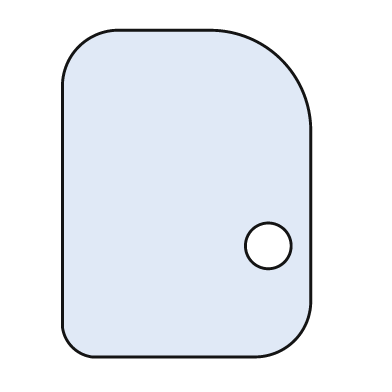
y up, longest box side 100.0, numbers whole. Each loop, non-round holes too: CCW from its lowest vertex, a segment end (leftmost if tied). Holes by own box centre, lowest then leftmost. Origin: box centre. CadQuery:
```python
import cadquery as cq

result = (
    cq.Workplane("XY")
    .moveTo(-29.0, -50.0)
    .lineTo(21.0, -50.0)
    .threePointArc((33.0, -45.0), (38.0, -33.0))
    .lineTo(38.0, 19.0)
    .threePointArc((29.0, 41.0), (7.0, 50.0))
    .lineTo(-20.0, 50.0)
    .threePointArc((-33.0, 45.0), (-38.0, 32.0))
    .lineTo(-38.0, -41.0)
    .threePointArc((-35.0, -47.0), (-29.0, -50.0))
    .close()
    .moveTo(25.0, -16.0)
    .circle(7.0)
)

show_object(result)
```